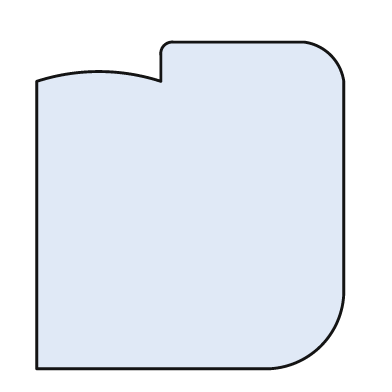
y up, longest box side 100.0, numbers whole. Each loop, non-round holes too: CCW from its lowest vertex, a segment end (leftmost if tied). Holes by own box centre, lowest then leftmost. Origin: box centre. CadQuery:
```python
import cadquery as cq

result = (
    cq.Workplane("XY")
    .moveTo(-47.0, -50.0)
    .lineTo(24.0, -50.0)
    .threePointArc((40.0, -43.0), (47.0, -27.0))
    .lineTo(47.0, 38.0)
    .threePointArc((43.0, 46.0), (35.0, 50.0))
    .lineTo(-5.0, 50.0)
    .threePointArc((-8.0, 49.0), (-9.0, 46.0))
    .lineTo(-9.0, 38.0)
    .threePointArc((-28.0, 41.0), (-47.0, 38.0))
    .close()
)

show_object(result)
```